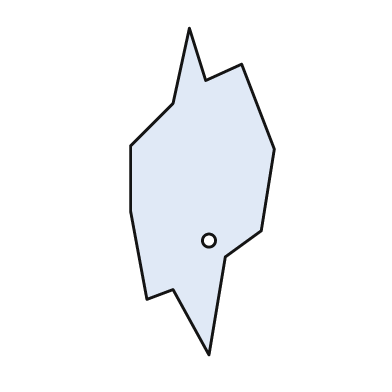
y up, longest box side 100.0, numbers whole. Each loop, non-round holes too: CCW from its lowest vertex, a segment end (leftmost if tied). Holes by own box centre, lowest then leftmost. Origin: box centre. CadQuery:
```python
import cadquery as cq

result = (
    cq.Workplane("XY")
    .moveTo(2.0, -50.0)
    .lineTo(7.0, -20.0)
    .lineTo(18.0, -12.0)
    .lineTo(22.0, 13.0)
    .lineTo(12.0, 39.0)
    .lineTo(1.0, 34.0)
    .lineTo(-4.0, 50.0)
    .lineTo(-9.0, 27.0)
    .lineTo(-22.0, 14.0)
    .lineTo(-22.0, -6.0)
    .lineTo(-17.0, -33.0)
    .lineTo(-9.0, -30.0)
    .close()
    .moveTo(2.0, -15.0)
    .circle(2.0)
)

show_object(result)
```